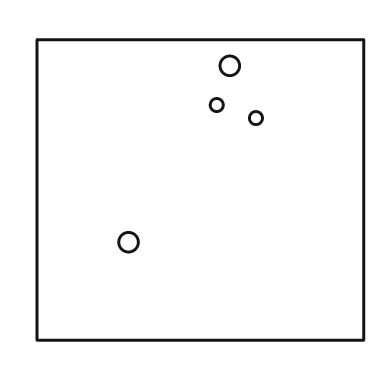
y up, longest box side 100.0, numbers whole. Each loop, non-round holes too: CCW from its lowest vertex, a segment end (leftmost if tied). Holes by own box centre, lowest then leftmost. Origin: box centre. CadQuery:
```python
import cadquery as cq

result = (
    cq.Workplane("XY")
    .moveTo(-50.0, -46.0)
    .lineTo(50.0, -46.0)
    .lineTo(50.0, 46.0)
    .lineTo(-50.0, 46.0)
    .close()
    .moveTo(-22.0, -16.0)
    .circle(3.0)
    .moveTo(17.0, 22.0)
    .circle(2.0)
    .moveTo(5.0, 26.0)
    .circle(2.0)
    .moveTo(9.0, 38.0)
    .circle(3.0)
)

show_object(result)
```